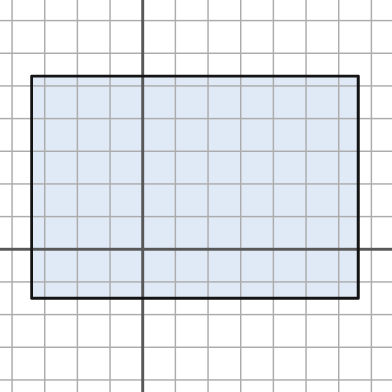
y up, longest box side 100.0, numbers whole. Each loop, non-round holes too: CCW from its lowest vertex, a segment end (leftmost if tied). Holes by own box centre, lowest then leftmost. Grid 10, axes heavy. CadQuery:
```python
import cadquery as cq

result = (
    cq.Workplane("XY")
    .moveTo(-34.0, -15.0)
    .lineTo(66.0, -15.0)
    .lineTo(66.0, 53.0)
    .lineTo(-34.0, 53.0)
    .close()
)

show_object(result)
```